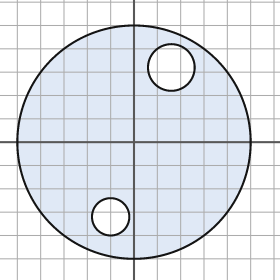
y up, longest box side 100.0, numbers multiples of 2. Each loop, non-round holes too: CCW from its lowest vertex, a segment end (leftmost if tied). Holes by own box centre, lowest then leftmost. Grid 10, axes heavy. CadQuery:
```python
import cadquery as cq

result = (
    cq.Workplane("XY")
    .moveTo(0.0, 0.0)
    .circle(50.0)
    .moveTo(-10.0, -32.0)
    .circle(8.0)
    .moveTo(16.0, 32.0)
    .circle(10.0)
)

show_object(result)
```